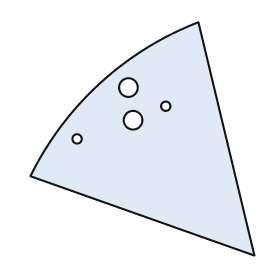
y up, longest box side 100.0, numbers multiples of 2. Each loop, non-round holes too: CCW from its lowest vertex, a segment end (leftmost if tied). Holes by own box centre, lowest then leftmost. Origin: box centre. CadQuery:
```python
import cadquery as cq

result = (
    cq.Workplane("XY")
    .moveTo(48.0, -50.0)
    .lineTo(24.0, 50.0)
    .threePointArc((-18.0, 24.0), (-48.0, -16.0))
    .close()
    .moveTo(-28.0, 0.0)
    .circle(2.0)
    .moveTo(-4.0, 8.0)
    .circle(4.0)
    .moveTo(10.0, 14.0)
    .circle(2.0)
    .moveTo(-6.0, 22.0)
    .circle(4.0)
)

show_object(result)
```